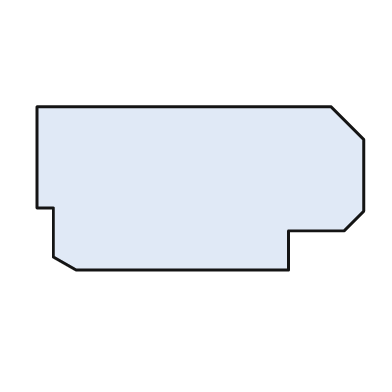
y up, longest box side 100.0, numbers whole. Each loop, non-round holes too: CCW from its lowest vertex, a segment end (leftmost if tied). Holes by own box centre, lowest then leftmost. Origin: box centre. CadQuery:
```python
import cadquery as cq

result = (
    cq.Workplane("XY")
    .moveTo(-38.0, -25.0)
    .lineTo(27.0, -25.0)
    .lineTo(27.0, -13.0)
    .lineTo(44.0, -13.0)
    .lineTo(50.0, -7.0)
    .lineTo(50.0, 15.0)
    .lineTo(40.0, 25.0)
    .lineTo(-50.0, 25.0)
    .lineTo(-50.0, -6.0)
    .lineTo(-45.0, -6.0)
    .lineTo(-45.0, -21.0)
    .close()
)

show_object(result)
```